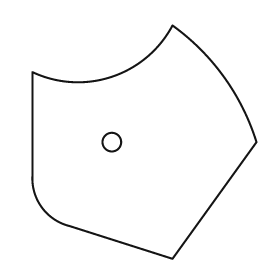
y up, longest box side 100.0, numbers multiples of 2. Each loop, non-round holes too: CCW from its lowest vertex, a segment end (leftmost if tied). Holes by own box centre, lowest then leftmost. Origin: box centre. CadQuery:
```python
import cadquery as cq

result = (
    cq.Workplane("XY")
    .moveTo(12.0, -50.0)
    .lineTo(48.0, 0.0)
    .threePointArc((34.0, 28.0), (12.0, 50.0))
    .threePointArc((-14.0, 28.0), (-48.0, 30.0))
    .lineTo(-48.0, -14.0)
    .threePointArc((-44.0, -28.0), (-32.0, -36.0))
    .close()
    .moveTo(-14.0, 0.0)
    .circle(4.0)
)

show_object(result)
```